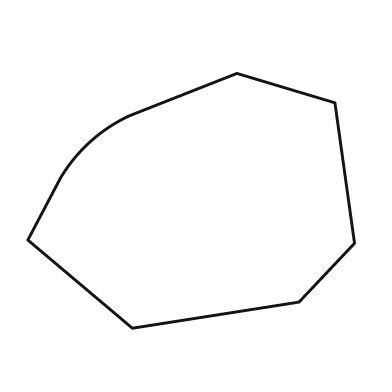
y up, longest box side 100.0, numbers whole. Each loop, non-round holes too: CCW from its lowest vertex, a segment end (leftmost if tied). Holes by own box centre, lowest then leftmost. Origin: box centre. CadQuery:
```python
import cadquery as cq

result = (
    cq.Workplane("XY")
    .moveTo(-18.0, -39.0)
    .lineTo(33.0, -31.0)
    .lineTo(50.0, -13.0)
    .lineTo(44.0, 30.0)
    .lineTo(14.0, 39.0)
    .lineTo(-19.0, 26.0)
    .threePointArc((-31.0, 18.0), (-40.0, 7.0))
    .lineTo(-50.0, -12.0)
    .close()
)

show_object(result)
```